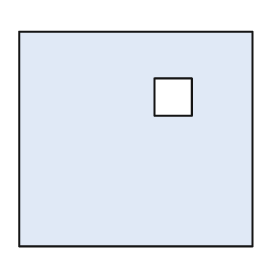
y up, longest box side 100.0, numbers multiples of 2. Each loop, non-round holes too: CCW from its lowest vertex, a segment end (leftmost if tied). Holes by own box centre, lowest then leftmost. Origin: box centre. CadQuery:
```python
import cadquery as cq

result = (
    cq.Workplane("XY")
    .moveTo(-50.0, -46.0)
    .lineTo(50.0, -46.0)
    .lineTo(50.0, 46.0)
    .lineTo(-50.0, 46.0)
    .close()
    .moveTo(8.0, 10.0)
    .lineTo(24.0, 10.0)
    .lineTo(24.0, 26.0)
    .lineTo(8.0, 26.0)
    .close()
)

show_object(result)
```